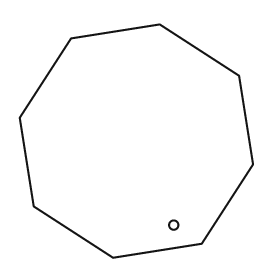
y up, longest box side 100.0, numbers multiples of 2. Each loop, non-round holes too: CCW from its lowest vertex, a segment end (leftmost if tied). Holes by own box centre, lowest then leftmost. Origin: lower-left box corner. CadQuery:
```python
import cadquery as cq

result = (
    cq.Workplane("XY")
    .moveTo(40.0, 0.0)
    .lineTo(78.0, 6.0)
    .lineTo(100.0, 40.0)
    .lineTo(94.0, 78.0)
    .lineTo(60.0, 100.0)
    .lineTo(22.0, 94.0)
    .lineTo(0.0, 60.0)
    .lineTo(6.0, 22.0)
    .close()
    .moveTo(66.0, 14.0)
    .circle(2.0)
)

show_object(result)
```